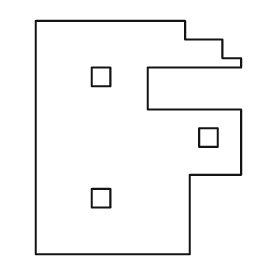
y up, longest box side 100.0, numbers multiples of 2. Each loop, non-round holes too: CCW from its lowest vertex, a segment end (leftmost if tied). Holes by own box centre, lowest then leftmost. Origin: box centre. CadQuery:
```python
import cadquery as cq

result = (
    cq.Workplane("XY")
    .moveTo(-44.0, -50.0)
    .lineTo(22.0, -50.0)
    .lineTo(22.0, -16.0)
    .lineTo(44.0, -16.0)
    .lineTo(44.0, 12.0)
    .lineTo(4.0, 12.0)
    .lineTo(4.0, 30.0)
    .lineTo(44.0, 30.0)
    .lineTo(44.0, 34.0)
    .lineTo(36.0, 34.0)
    .lineTo(36.0, 42.0)
    .lineTo(20.0, 42.0)
    .lineTo(20.0, 50.0)
    .lineTo(-44.0, 50.0)
    .close()
    .moveTo(-20.0, -30.0)
    .lineTo(-12.0, -30.0)
    .lineTo(-12.0, -22.0)
    .lineTo(-20.0, -22.0)
    .close()
    .moveTo(26.0, -4.0)
    .lineTo(34.0, -4.0)
    .lineTo(34.0, 4.0)
    .lineTo(26.0, 4.0)
    .close()
    .moveTo(-20.0, 22.0)
    .lineTo(-12.0, 22.0)
    .lineTo(-12.0, 30.0)
    .lineTo(-20.0, 30.0)
    .close()
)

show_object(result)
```